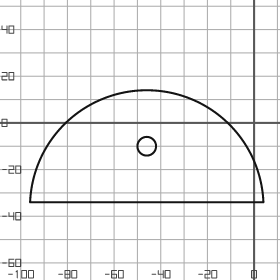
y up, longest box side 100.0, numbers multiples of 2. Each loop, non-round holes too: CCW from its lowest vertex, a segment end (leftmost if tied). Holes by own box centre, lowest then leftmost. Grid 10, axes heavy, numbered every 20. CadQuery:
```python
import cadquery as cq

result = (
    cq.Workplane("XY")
    .moveTo(-96.0, -34.0)
    .lineTo(4.0, -34.0)
    .threePointArc((-46.0, 14.0), (-96.0, -34.0))
    .close()
    .moveTo(-46.0, -10.0)
    .circle(4.0)
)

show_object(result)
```